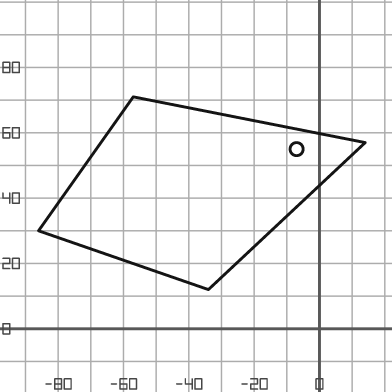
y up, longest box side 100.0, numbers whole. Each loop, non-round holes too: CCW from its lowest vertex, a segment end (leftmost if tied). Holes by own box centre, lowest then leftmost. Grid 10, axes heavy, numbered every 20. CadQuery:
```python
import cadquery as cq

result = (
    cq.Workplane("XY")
    .moveTo(-34.0, 12.0)
    .lineTo(14.0, 57.0)
    .lineTo(-57.0, 71.0)
    .lineTo(-86.0, 30.0)
    .close()
    .moveTo(-7.0, 55.0)
    .circle(2.0)
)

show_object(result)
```